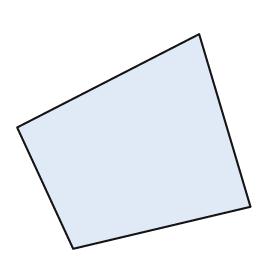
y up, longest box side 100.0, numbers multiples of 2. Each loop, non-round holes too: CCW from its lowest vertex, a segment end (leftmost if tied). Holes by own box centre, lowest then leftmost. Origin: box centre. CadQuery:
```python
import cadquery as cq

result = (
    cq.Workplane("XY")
    .moveTo(-26.0, -46.0)
    .lineTo(50.0, -28.0)
    .lineTo(28.0, 46.0)
    .lineTo(-50.0, 6.0)
    .close()
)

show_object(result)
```